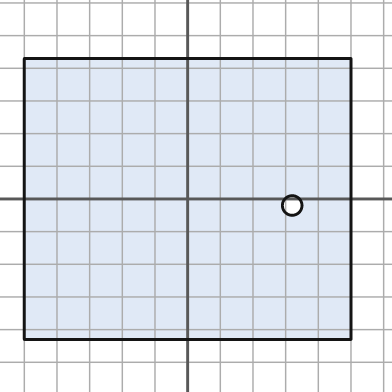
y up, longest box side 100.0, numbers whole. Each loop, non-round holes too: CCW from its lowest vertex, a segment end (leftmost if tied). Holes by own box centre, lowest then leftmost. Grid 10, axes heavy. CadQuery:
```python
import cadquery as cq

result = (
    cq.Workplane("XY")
    .moveTo(-50.0, -43.0)
    .lineTo(50.0, -43.0)
    .lineTo(50.0, 43.0)
    .lineTo(-50.0, 43.0)
    .close()
    .moveTo(32.0, -2.0)
    .circle(3.0)
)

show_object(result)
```